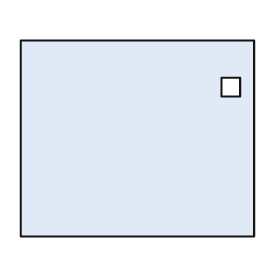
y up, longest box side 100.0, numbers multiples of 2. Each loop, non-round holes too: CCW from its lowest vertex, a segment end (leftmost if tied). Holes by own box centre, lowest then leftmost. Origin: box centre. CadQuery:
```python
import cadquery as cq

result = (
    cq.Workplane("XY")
    .moveTo(-50.0, -42.0)
    .lineTo(50.0, -42.0)
    .lineTo(50.0, 42.0)
    .lineTo(-50.0, 42.0)
    .close()
    .moveTo(36.0, 18.0)
    .lineTo(44.0, 18.0)
    .lineTo(44.0, 26.0)
    .lineTo(36.0, 26.0)
    .close()
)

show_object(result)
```